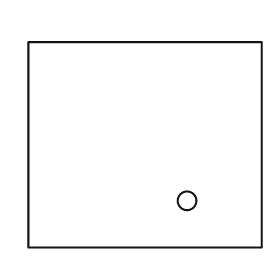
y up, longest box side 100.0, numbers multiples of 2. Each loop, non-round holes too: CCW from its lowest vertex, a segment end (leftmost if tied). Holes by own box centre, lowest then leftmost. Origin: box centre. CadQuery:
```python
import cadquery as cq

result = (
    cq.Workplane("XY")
    .moveTo(-50.0, -44.0)
    .lineTo(50.0, -44.0)
    .lineTo(50.0, 44.0)
    .lineTo(-50.0, 44.0)
    .close()
    .moveTo(18.0, -24.0)
    .circle(4.0)
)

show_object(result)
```